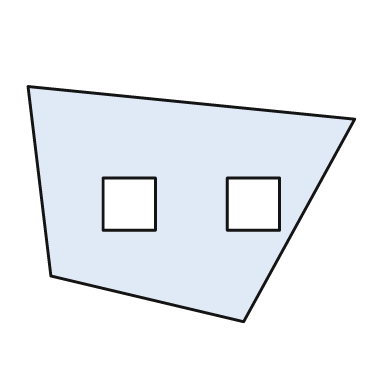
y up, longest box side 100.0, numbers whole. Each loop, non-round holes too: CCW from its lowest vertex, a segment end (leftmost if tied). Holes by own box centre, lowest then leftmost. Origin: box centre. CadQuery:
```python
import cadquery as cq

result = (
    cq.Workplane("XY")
    .moveTo(16.0, -36.0)
    .lineTo(50.0, 26.0)
    .lineTo(-50.0, 36.0)
    .lineTo(-43.0, -22.0)
    .close()
    .moveTo(-27.0, -8.0)
    .lineTo(-11.0, -8.0)
    .lineTo(-11.0, 8.0)
    .lineTo(-27.0, 8.0)
    .close()
    .moveTo(11.0, -8.0)
    .lineTo(27.0, -8.0)
    .lineTo(27.0, 8.0)
    .lineTo(11.0, 8.0)
    .close()
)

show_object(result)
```